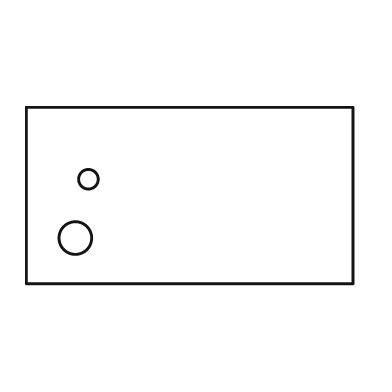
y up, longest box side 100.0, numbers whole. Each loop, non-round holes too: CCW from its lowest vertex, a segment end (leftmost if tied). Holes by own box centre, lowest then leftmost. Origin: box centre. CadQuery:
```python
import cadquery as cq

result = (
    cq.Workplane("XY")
    .moveTo(-50.0, -27.0)
    .lineTo(50.0, -27.0)
    .lineTo(50.0, 27.0)
    .lineTo(-50.0, 27.0)
    .close()
    .moveTo(-35.0, -13.0)
    .circle(5.0)
    .moveTo(-31.0, 5.0)
    .circle(3.0)
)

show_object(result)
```